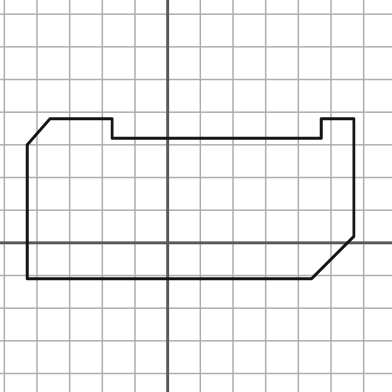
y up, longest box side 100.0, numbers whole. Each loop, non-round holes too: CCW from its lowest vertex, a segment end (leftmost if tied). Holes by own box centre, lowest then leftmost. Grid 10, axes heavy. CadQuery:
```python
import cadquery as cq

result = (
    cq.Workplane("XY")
    .moveTo(-43.0, -11.0)
    .lineTo(44.0, -11.0)
    .lineTo(57.0, 2.0)
    .lineTo(57.0, 38.0)
    .lineTo(47.0, 38.0)
    .lineTo(47.0, 32.0)
    .lineTo(-17.0, 32.0)
    .lineTo(-17.0, 38.0)
    .lineTo(-36.0, 38.0)
    .lineTo(-43.0, 30.0)
    .close()
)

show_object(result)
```